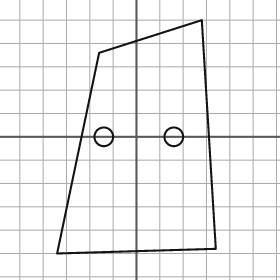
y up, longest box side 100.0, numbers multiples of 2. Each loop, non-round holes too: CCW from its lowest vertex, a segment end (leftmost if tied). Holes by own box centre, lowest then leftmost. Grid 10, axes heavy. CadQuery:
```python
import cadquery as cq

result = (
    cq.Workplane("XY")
    .moveTo(-34.0, -50.0)
    .lineTo(34.0, -48.0)
    .lineTo(28.0, 50.0)
    .lineTo(-16.0, 36.0)
    .close()
    .moveTo(-14.0, 0.0)
    .circle(4.0)
    .moveTo(16.0, 0.0)
    .circle(4.0)
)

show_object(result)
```